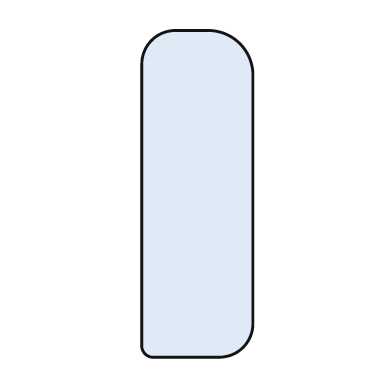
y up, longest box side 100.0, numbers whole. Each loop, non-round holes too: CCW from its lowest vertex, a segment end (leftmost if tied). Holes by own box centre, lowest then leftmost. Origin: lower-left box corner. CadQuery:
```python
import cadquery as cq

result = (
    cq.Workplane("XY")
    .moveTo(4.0, 0.0)
    .lineTo(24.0, 0.0)
    .threePointArc((31.0, 3.0), (34.0, 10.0))
    .lineTo(34.0, 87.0)
    .threePointArc((30.0, 96.0), (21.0, 100.0))
    .lineTo(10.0, 100.0)
    .threePointArc((3.0, 97.0), (0.0, 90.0))
    .lineTo(0.0, 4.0)
    .threePointArc((1.0, 1.0), (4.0, 0.0))
    .close()
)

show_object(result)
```